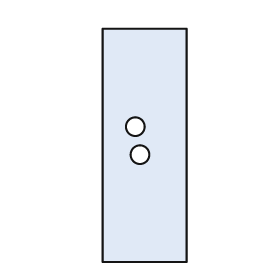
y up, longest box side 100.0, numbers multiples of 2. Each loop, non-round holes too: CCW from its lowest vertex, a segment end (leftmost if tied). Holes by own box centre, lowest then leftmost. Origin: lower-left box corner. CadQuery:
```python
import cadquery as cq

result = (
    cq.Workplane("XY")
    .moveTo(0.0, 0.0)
    .lineTo(36.0, 0.0)
    .lineTo(36.0, 100.0)
    .lineTo(0.0, 100.0)
    .close()
    .moveTo(16.0, 46.0)
    .circle(4.0)
    .moveTo(14.0, 58.0)
    .circle(4.0)
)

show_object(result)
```